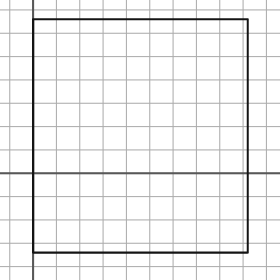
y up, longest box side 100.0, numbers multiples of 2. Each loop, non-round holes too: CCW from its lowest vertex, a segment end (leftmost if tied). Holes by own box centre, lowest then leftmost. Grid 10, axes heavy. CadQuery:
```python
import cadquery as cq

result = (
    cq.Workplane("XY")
    .moveTo(0.0, -34.0)
    .lineTo(92.0, -34.0)
    .lineTo(92.0, 66.0)
    .lineTo(0.0, 66.0)
    .close()
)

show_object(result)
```